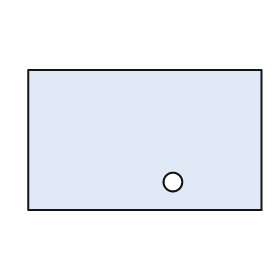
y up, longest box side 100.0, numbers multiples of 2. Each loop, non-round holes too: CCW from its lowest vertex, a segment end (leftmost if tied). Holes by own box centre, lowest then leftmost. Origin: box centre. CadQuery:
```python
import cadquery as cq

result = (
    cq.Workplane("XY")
    .moveTo(-50.0, -30.0)
    .lineTo(50.0, -30.0)
    .lineTo(50.0, 30.0)
    .lineTo(-50.0, 30.0)
    .close()
    .moveTo(12.0, -18.0)
    .circle(4.0)
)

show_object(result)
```